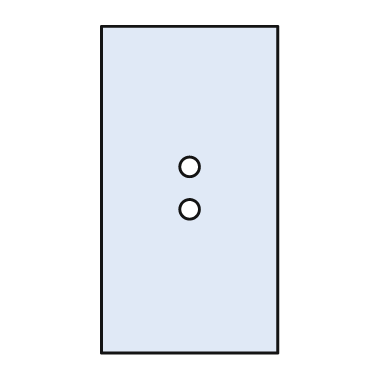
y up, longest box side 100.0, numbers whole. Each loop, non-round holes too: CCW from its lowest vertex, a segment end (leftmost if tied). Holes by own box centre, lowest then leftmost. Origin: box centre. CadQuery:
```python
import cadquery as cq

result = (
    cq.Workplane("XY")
    .moveTo(-27.0, -50.0)
    .lineTo(27.0, -50.0)
    .lineTo(27.0, 50.0)
    .lineTo(-27.0, 50.0)
    .close()
    .moveTo(0.0, -6.0)
    .circle(3.0)
    .moveTo(0.0, 7.0)
    .circle(3.0)
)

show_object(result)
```